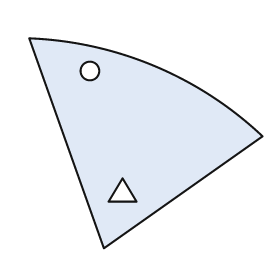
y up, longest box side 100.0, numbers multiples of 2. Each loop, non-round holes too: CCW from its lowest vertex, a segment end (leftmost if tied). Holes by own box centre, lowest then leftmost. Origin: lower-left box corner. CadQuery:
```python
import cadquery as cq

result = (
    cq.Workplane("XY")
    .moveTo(32.0, 0.0)
    .lineTo(100.0, 48.0)
    .threePointArc((54.0, 78.0), (0.0, 90.0))
    .close()
    .moveTo(34.0, 20.0)
    .lineTo(46.0, 20.0)
    .lineTo(40.0, 30.0)
    .close()
    .moveTo(26.0, 76.0)
    .circle(4.0)
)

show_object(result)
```